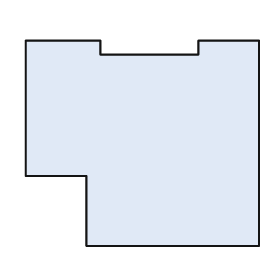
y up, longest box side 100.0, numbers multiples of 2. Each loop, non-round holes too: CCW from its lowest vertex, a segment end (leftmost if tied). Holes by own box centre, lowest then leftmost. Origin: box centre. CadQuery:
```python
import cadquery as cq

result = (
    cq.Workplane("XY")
    .moveTo(-24.0, -44.0)
    .lineTo(50.0, -44.0)
    .lineTo(50.0, 44.0)
    .lineTo(24.0, 44.0)
    .lineTo(24.0, 38.0)
    .lineTo(-18.0, 38.0)
    .lineTo(-18.0, 44.0)
    .lineTo(-50.0, 44.0)
    .lineTo(-50.0, -14.0)
    .lineTo(-24.0, -14.0)
    .close()
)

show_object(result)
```